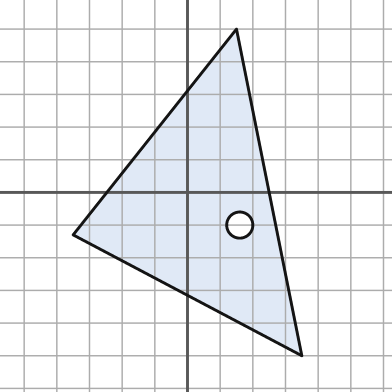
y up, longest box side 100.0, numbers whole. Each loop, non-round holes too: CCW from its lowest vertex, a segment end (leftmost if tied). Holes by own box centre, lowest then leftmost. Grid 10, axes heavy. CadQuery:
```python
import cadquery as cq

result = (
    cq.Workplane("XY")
    .moveTo(35.0, -50.0)
    .lineTo(15.0, 50.0)
    .lineTo(-35.0, -13.0)
    .close()
    .moveTo(16.0, -10.0)
    .circle(4.0)
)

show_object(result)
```